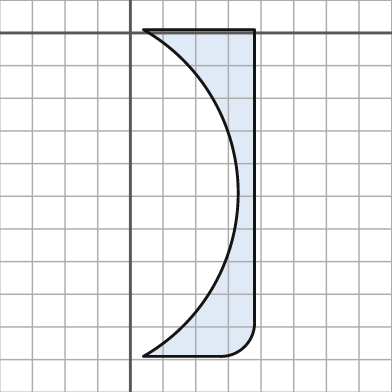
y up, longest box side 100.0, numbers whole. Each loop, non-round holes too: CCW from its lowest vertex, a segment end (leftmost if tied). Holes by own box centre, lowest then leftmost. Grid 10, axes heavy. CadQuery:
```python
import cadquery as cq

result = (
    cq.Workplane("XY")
    .moveTo(4.0, -99.0)
    .lineTo(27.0, -99.0)
    .threePointArc((35.0, -96.0), (38.0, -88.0))
    .lineTo(38.0, 1.0)
    .lineTo(4.0, 1.0)
    .threePointArc((33.0, -49.0), (4.0, -99.0))
    .close()
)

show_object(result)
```